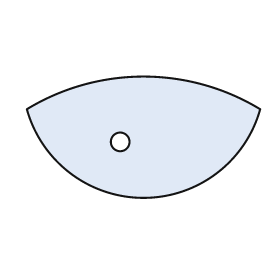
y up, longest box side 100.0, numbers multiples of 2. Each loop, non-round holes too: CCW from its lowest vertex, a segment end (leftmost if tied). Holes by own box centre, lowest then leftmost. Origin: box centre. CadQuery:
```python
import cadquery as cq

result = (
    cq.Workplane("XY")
    .moveTo(-50.0, 12.0)
    .threePointArc((0.0, -26.0), (50.0, 12.0))
    .threePointArc((0.0, 26.0), (-50.0, 12.0))
    .close()
    .moveTo(-10.0, -2.0)
    .circle(4.0)
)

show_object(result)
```